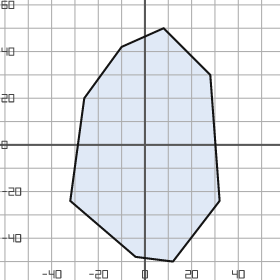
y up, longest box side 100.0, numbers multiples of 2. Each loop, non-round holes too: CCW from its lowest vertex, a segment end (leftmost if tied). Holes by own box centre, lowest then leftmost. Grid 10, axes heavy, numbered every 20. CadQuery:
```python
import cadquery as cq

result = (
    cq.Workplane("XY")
    .moveTo(12.0, -50.0)
    .lineTo(32.0, -24.0)
    .lineTo(28.0, 30.0)
    .lineTo(8.0, 50.0)
    .lineTo(-10.0, 42.0)
    .lineTo(-26.0, 20.0)
    .lineTo(-32.0, -24.0)
    .lineTo(-4.0, -48.0)
    .close()
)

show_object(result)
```